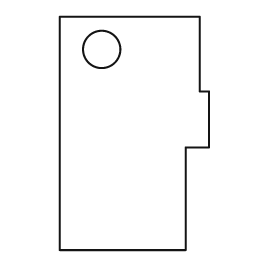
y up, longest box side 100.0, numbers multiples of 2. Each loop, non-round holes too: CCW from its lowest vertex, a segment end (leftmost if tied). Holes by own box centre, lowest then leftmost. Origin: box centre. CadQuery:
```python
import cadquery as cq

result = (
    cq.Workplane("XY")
    .moveTo(-32.0, -50.0)
    .lineTo(22.0, -50.0)
    .lineTo(22.0, -6.0)
    .lineTo(32.0, -6.0)
    .lineTo(32.0, 18.0)
    .lineTo(28.0, 18.0)
    .lineTo(28.0, 50.0)
    .lineTo(-32.0, 50.0)
    .close()
    .moveTo(-14.0, 36.0)
    .circle(8.0)
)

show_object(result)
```